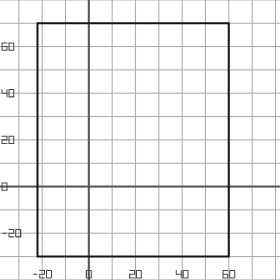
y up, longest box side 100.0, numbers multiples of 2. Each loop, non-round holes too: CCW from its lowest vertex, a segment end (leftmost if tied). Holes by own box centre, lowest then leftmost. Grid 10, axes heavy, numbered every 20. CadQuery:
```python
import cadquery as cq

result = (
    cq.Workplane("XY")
    .moveTo(-22.0, -30.0)
    .lineTo(60.0, -30.0)
    .lineTo(60.0, 70.0)
    .lineTo(-22.0, 70.0)
    .close()
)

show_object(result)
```